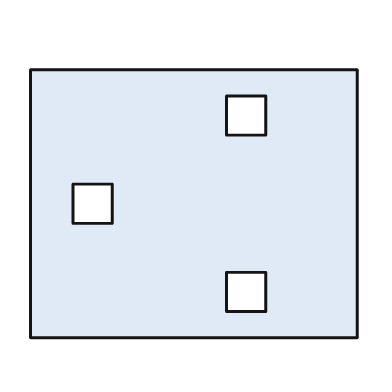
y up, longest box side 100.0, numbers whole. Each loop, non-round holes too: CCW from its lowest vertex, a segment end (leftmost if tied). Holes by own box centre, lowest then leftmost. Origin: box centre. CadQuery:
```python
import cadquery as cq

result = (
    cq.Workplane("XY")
    .moveTo(-50.0, -41.0)
    .lineTo(50.0, -41.0)
    .lineTo(50.0, 41.0)
    .lineTo(-50.0, 41.0)
    .close()
    .moveTo(10.0, -33.0)
    .lineTo(22.0, -33.0)
    .lineTo(22.0, -21.0)
    .lineTo(10.0, -21.0)
    .close()
    .moveTo(-37.0, -6.0)
    .lineTo(-25.0, -6.0)
    .lineTo(-25.0, 6.0)
    .lineTo(-37.0, 6.0)
    .close()
    .moveTo(10.0, 21.0)
    .lineTo(22.0, 21.0)
    .lineTo(22.0, 33.0)
    .lineTo(10.0, 33.0)
    .close()
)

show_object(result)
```